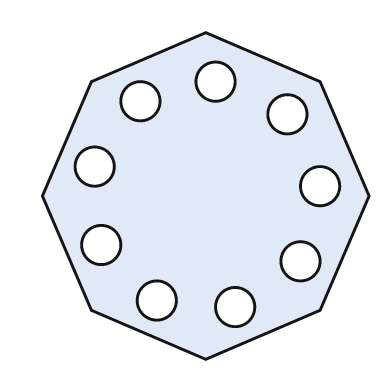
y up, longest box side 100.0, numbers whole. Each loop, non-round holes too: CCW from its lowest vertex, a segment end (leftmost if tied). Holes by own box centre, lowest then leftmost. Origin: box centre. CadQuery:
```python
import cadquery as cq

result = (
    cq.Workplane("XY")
    .moveTo(0.0, -50.0)
    .lineTo(35.0, -35.0)
    .lineTo(50.0, 0.0)
    .lineTo(35.0, 35.0)
    .lineTo(0.0, 50.0)
    .lineTo(-35.0, 35.0)
    .lineTo(-50.0, 0.0)
    .lineTo(-35.0, -35.0)
    .close()
    .moveTo(9.0, -34.0)
    .circle(6.0)
    .moveTo(-15.0, -32.0)
    .circle(6.0)
    .moveTo(29.0, -20.0)
    .circle(6.0)
    .moveTo(-32.0, -15.0)
    .circle(6.0)
    .moveTo(35.0, 3.0)
    .circle(6.0)
    .moveTo(-34.0, 9.0)
    .circle(6.0)
    .moveTo(25.0, 25.0)
    .circle(6.0)
    .moveTo(-20.0, 29.0)
    .circle(6.0)
    .moveTo(3.0, 35.0)
    .circle(6.0)
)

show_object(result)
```